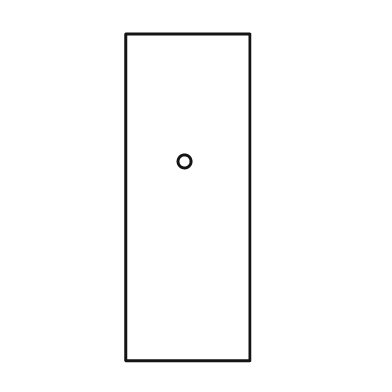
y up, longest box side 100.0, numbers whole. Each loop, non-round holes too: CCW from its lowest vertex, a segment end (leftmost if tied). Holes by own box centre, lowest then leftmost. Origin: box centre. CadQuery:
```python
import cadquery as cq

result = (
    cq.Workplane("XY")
    .moveTo(-19.0, -50.0)
    .lineTo(19.0, -50.0)
    .lineTo(19.0, 50.0)
    .lineTo(-19.0, 50.0)
    .close()
    .moveTo(-1.0, 11.0)
    .circle(2.0)
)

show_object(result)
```